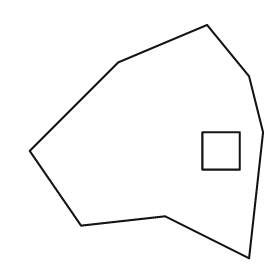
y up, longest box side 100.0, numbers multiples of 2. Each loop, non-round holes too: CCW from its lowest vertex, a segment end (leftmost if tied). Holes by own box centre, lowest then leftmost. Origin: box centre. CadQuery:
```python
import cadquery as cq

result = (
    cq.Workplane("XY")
    .moveTo(44.0, -50.0)
    .lineTo(50.0, 4.0)
    .lineTo(44.0, 28.0)
    .lineTo(26.0, 50.0)
    .lineTo(-12.0, 34.0)
    .lineTo(-50.0, -4.0)
    .lineTo(-28.0, -36.0)
    .lineTo(8.0, -32.0)
    .close()
    .moveTo(24.0, -12.0)
    .lineTo(40.0, -12.0)
    .lineTo(40.0, 4.0)
    .lineTo(24.0, 4.0)
    .close()
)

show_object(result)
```